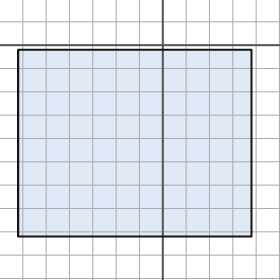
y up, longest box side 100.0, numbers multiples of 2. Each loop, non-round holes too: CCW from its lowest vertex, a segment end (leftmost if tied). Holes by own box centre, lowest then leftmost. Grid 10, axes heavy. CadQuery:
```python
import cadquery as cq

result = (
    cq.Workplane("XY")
    .moveTo(-62.0, -82.0)
    .lineTo(38.0, -82.0)
    .lineTo(38.0, -2.0)
    .lineTo(-62.0, -2.0)
    .close()
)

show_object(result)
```